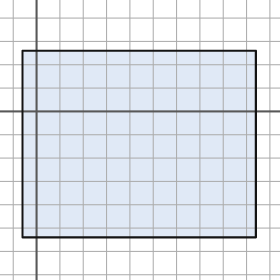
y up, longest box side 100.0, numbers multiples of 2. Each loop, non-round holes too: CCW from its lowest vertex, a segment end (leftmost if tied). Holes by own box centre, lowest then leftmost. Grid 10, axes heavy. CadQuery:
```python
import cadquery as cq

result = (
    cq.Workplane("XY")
    .moveTo(-6.0, -54.0)
    .lineTo(94.0, -54.0)
    .lineTo(94.0, 26.0)
    .lineTo(-6.0, 26.0)
    .close()
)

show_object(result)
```